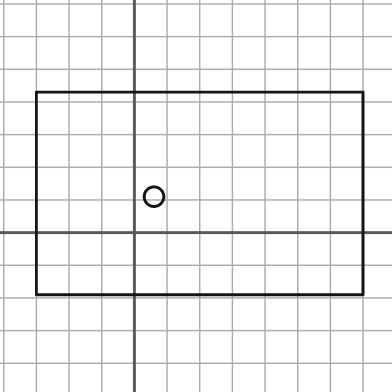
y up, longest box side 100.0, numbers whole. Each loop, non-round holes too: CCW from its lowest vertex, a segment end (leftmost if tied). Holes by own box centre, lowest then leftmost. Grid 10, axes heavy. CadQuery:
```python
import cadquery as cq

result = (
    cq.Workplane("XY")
    .moveTo(-30.0, -19.0)
    .lineTo(70.0, -19.0)
    .lineTo(70.0, 43.0)
    .lineTo(-30.0, 43.0)
    .close()
    .moveTo(6.0, 11.0)
    .circle(3.0)
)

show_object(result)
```